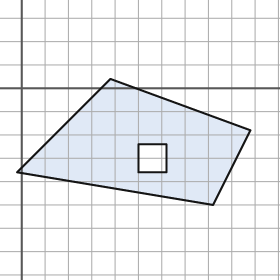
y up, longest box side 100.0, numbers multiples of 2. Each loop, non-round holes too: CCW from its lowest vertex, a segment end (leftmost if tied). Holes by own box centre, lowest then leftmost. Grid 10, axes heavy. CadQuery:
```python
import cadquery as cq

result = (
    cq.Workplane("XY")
    .moveTo(82.0, -50.0)
    .lineTo(98.0, -18.0)
    .lineTo(38.0, 4.0)
    .lineTo(-2.0, -36.0)
    .close()
    .moveTo(50.0, -36.0)
    .lineTo(62.0, -36.0)
    .lineTo(62.0, -24.0)
    .lineTo(50.0, -24.0)
    .close()
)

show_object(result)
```